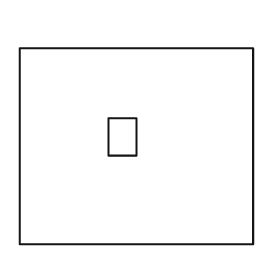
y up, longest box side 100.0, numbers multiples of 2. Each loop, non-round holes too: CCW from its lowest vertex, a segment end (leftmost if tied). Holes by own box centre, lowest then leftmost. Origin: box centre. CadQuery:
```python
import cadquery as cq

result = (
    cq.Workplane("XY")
    .moveTo(-50.0, -42.0)
    .lineTo(50.0, -42.0)
    .lineTo(50.0, 42.0)
    .lineTo(-50.0, 42.0)
    .close()
    .moveTo(-12.0, -4.0)
    .lineTo(0.0, -4.0)
    .lineTo(0.0, 12.0)
    .lineTo(-12.0, 12.0)
    .close()
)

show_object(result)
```